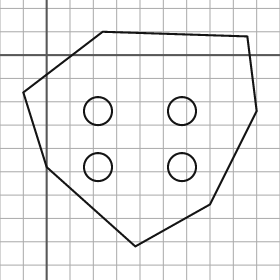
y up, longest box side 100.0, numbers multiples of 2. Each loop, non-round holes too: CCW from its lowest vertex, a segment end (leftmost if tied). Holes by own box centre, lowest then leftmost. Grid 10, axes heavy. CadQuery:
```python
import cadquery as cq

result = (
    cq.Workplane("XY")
    .moveTo(38.0, -82.0)
    .lineTo(70.0, -64.0)
    .lineTo(90.0, -24.0)
    .lineTo(86.0, 8.0)
    .lineTo(24.0, 10.0)
    .lineTo(-10.0, -16.0)
    .lineTo(0.0, -48.0)
    .close()
    .moveTo(22.0, -48.0)
    .circle(6.0)
    .moveTo(58.0, -48.0)
    .circle(6.0)
    .moveTo(22.0, -24.0)
    .circle(6.0)
    .moveTo(58.0, -24.0)
    .circle(6.0)
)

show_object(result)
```